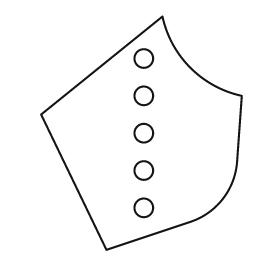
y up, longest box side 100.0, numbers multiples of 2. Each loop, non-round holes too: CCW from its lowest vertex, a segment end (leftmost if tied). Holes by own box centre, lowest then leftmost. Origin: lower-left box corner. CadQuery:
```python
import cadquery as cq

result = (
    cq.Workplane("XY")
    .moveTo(28.0, 0.0)
    .lineTo(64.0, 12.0)
    .threePointArc((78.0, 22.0), (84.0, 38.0))
    .lineTo(86.0, 66.0)
    .threePointArc((64.0, 78.0), (52.0, 100.0))
    .lineTo(0.0, 58.0)
    .close()
    .moveTo(44.0, 18.0)
    .circle(4.0)
    .moveTo(44.0, 34.0)
    .circle(4.0)
    .moveTo(44.0, 50.0)
    .circle(4.0)
    .moveTo(44.0, 66.0)
    .circle(4.0)
    .moveTo(44.0, 82.0)
    .circle(4.0)
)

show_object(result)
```